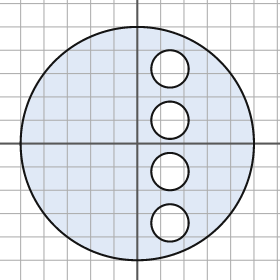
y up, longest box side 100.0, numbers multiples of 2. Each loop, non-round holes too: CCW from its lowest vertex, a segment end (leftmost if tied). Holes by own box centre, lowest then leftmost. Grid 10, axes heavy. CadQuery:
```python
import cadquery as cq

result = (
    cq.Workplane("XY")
    .moveTo(0.0, 0.0)
    .circle(50.0)
    .moveTo(14.0, -34.0)
    .circle(8.0)
    .moveTo(14.0, -12.0)
    .circle(8.0)
    .moveTo(14.0, 10.0)
    .circle(8.0)
    .moveTo(14.0, 32.0)
    .circle(8.0)
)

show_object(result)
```